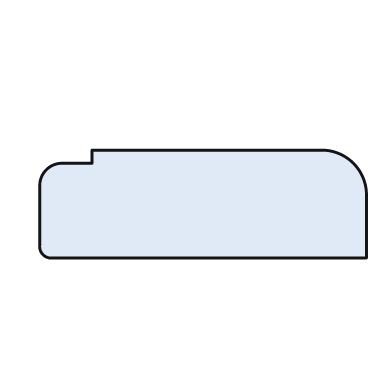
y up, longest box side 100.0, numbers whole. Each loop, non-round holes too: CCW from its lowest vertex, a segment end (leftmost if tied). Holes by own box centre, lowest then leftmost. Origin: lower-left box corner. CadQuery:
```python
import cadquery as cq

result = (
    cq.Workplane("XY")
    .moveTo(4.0, 0.0)
    .lineTo(100.0, 0.0)
    .lineTo(100.0, 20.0)
    .threePointArc((96.0, 29.0), (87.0, 33.0))
    .lineTo(16.0, 33.0)
    .lineTo(16.0, 29.0)
    .lineTo(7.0, 29.0)
    .threePointArc((2.0, 27.0), (0.0, 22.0))
    .lineTo(0.0, 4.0)
    .threePointArc((1.0, 1.0), (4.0, 0.0))
    .close()
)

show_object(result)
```